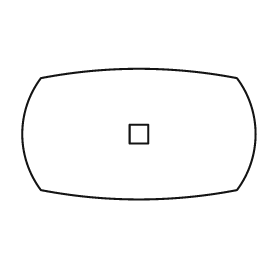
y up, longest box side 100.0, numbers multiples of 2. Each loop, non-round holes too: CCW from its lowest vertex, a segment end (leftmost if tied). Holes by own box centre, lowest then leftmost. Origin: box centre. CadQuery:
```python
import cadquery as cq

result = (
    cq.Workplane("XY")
    .moveTo(-42.0, -24.0)
    .threePointArc((0.0, -28.0), (42.0, -24.0))
    .threePointArc((50.0, 0.0), (42.0, 24.0))
    .threePointArc((0.0, 28.0), (-42.0, 24.0))
    .threePointArc((-50.0, 0.0), (-42.0, -24.0))
    .close()
    .moveTo(-4.0, -4.0)
    .lineTo(4.0, -4.0)
    .lineTo(4.0, 4.0)
    .lineTo(-4.0, 4.0)
    .close()
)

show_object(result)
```